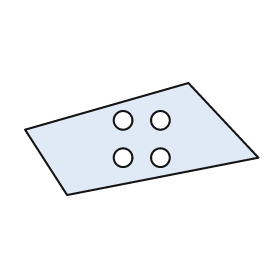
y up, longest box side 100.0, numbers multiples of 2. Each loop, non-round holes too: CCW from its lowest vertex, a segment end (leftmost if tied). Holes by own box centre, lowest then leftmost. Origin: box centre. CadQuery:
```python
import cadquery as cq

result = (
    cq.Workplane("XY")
    .moveTo(-32.0, -24.0)
    .lineTo(50.0, -8.0)
    .lineTo(20.0, 24.0)
    .lineTo(-50.0, 4.0)
    .close()
    .moveTo(-8.0, -8.0)
    .circle(4.0)
    .moveTo(8.0, -8.0)
    .circle(4.0)
    .moveTo(-8.0, 8.0)
    .circle(4.0)
    .moveTo(8.0, 8.0)
    .circle(4.0)
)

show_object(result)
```